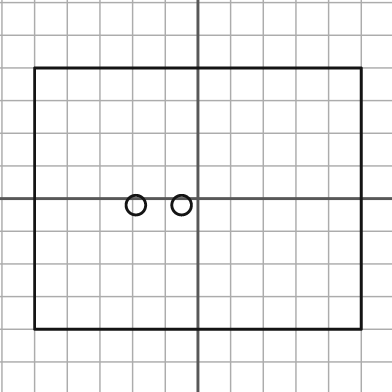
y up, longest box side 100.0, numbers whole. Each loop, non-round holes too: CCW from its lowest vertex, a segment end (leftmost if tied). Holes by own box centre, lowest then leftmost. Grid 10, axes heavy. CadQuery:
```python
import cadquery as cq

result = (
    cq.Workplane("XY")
    .moveTo(-50.0, -40.0)
    .lineTo(50.0, -40.0)
    .lineTo(50.0, 40.0)
    .lineTo(-50.0, 40.0)
    .close()
    .moveTo(-19.0, -2.0)
    .circle(3.0)
    .moveTo(-5.0, -2.0)
    .circle(3.0)
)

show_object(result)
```